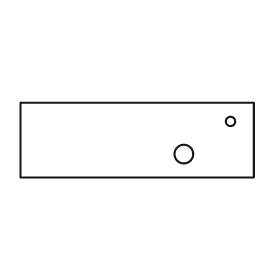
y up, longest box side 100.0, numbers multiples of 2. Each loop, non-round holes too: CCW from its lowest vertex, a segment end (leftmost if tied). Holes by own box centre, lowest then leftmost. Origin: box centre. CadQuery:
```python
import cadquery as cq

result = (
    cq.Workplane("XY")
    .moveTo(-50.0, -16.0)
    .lineTo(50.0, -16.0)
    .lineTo(50.0, 16.0)
    .lineTo(-50.0, 16.0)
    .close()
    .moveTo(20.0, -6.0)
    .circle(4.0)
    .moveTo(40.0, 8.0)
    .circle(2.0)
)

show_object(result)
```